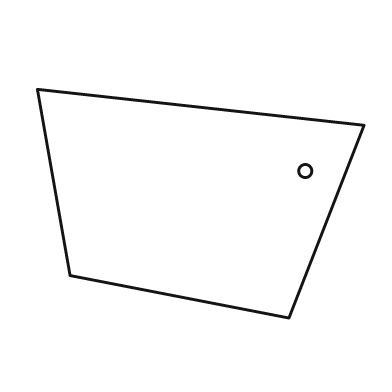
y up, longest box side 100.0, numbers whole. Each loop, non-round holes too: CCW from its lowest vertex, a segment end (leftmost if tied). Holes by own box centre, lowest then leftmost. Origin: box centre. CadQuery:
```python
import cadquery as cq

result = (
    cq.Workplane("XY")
    .moveTo(27.0, -35.0)
    .lineTo(50.0, 24.0)
    .lineTo(-50.0, 35.0)
    .lineTo(-40.0, -22.0)
    .close()
    .moveTo(32.0, 10.0)
    .circle(2.0)
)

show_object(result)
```